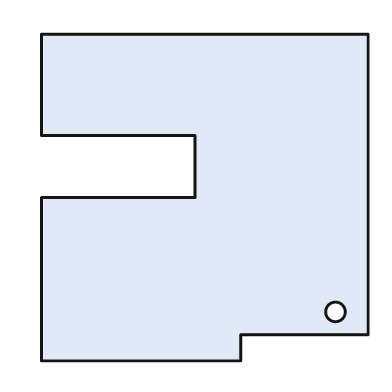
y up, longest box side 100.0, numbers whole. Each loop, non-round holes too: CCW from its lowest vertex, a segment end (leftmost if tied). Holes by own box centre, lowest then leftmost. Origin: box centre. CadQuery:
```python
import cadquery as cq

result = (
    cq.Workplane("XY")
    .moveTo(-50.0, -50.0)
    .lineTo(11.0, -50.0)
    .lineTo(11.0, -42.0)
    .lineTo(50.0, -42.0)
    .lineTo(50.0, 50.0)
    .lineTo(-50.0, 50.0)
    .lineTo(-50.0, 19.0)
    .lineTo(-3.0, 19.0)
    .lineTo(-3.0, 0.0)
    .lineTo(-50.0, 0.0)
    .close()
    .moveTo(40.0, -35.0)
    .circle(3.0)
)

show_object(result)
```